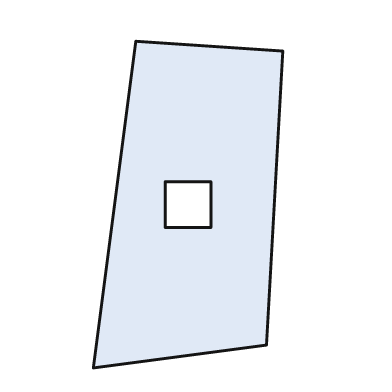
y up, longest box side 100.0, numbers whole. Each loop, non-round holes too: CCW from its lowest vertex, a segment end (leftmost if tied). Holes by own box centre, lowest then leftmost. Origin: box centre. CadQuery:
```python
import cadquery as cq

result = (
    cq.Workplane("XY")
    .moveTo(-29.0, -50.0)
    .lineTo(24.0, -43.0)
    .lineTo(29.0, 47.0)
    .lineTo(-16.0, 50.0)
    .close()
    .moveTo(-7.0, -7.0)
    .lineTo(7.0, -7.0)
    .lineTo(7.0, 7.0)
    .lineTo(-7.0, 7.0)
    .close()
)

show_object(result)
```